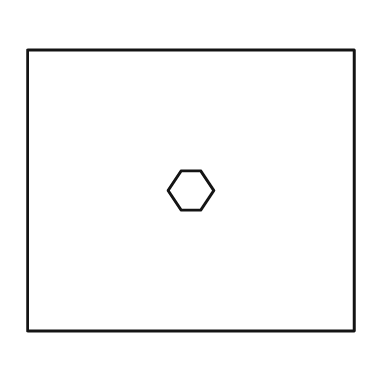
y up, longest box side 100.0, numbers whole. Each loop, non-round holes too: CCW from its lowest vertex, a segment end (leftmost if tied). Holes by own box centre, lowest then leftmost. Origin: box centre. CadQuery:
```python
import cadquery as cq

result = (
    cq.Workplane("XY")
    .moveTo(-50.0, -43.0)
    .lineTo(50.0, -43.0)
    .lineTo(50.0, 43.0)
    .lineTo(-50.0, 43.0)
    .close()
    .moveTo(-3.0, -6.0)
    .lineTo(3.0, -6.0)
    .lineTo(7.0, 0.0)
    .lineTo(3.0, 6.0)
    .lineTo(-3.0, 6.0)
    .lineTo(-7.0, 0.0)
    .close()
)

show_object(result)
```